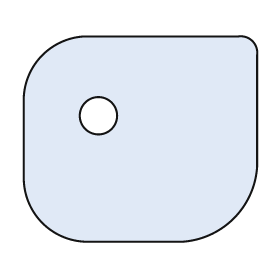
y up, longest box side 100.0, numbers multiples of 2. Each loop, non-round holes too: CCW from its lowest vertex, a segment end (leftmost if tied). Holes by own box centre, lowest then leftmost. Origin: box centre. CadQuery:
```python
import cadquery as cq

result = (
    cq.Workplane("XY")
    .moveTo(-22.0, -44.0)
    .lineTo(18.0, -44.0)
    .threePointArc((40.0, -34.0), (50.0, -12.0))
    .lineTo(50.0, 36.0)
    .threePointArc((48.0, 42.0), (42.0, 44.0))
    .lineTo(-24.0, 44.0)
    .threePointArc((-42.0, 36.0), (-50.0, 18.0))
    .lineTo(-50.0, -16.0)
    .threePointArc((-42.0, -36.0), (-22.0, -44.0))
    .close()
    .moveTo(-18.0, 10.0)
    .circle(8.0)
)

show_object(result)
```